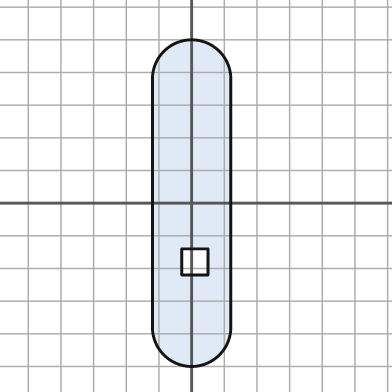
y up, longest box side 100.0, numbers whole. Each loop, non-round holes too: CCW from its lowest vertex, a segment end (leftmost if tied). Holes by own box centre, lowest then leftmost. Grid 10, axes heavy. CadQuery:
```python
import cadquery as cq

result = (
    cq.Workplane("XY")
    .moveTo(-12.0, -38.0)
    .threePointArc((0.0, -50.0), (12.0, -38.0))
    .lineTo(12.0, 38.0)
    .threePointArc((0.0, 50.0), (-12.0, 38.0))
    .close()
    .moveTo(-3.0, -22.0)
    .lineTo(5.0, -22.0)
    .lineTo(5.0, -14.0)
    .lineTo(-3.0, -14.0)
    .close()
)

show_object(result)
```